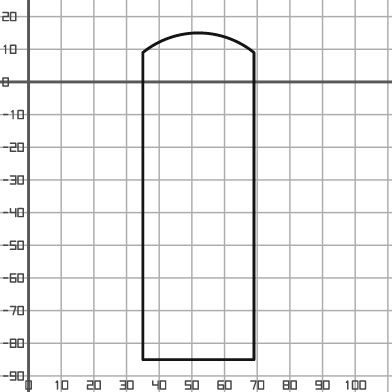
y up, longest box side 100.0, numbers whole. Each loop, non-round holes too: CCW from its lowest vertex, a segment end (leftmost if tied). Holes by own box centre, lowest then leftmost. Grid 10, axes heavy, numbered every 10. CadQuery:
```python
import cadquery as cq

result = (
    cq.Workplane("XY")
    .moveTo(35.0, -85.0)
    .lineTo(69.0, -85.0)
    .lineTo(69.0, 9.0)
    .threePointArc((52.0, 15.0), (35.0, 9.0))
    .close()
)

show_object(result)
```